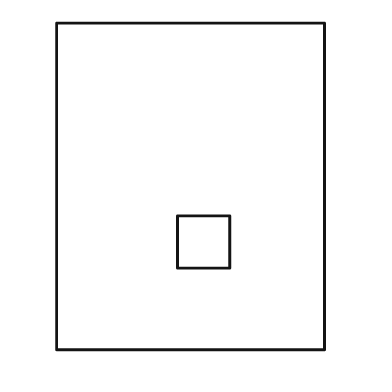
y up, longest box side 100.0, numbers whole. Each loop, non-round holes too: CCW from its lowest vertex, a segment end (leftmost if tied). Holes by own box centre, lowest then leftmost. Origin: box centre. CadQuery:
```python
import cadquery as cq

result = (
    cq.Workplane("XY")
    .moveTo(-41.0, -50.0)
    .lineTo(41.0, -50.0)
    .lineTo(41.0, 50.0)
    .lineTo(-41.0, 50.0)
    .close()
    .moveTo(-4.0, -25.0)
    .lineTo(12.0, -25.0)
    .lineTo(12.0, -9.0)
    .lineTo(-4.0, -9.0)
    .close()
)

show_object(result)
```